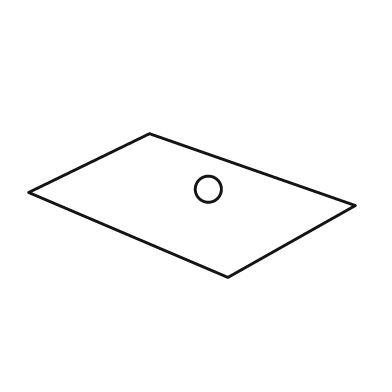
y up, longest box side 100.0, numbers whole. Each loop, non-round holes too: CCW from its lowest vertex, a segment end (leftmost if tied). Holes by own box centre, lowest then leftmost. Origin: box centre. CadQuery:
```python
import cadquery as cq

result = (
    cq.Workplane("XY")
    .moveTo(11.0, -22.0)
    .lineTo(50.0, 0.0)
    .lineTo(-13.0, 22.0)
    .lineTo(-50.0, 4.0)
    .close()
    .moveTo(5.0, 5.0)
    .circle(4.0)
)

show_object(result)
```